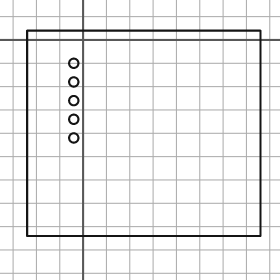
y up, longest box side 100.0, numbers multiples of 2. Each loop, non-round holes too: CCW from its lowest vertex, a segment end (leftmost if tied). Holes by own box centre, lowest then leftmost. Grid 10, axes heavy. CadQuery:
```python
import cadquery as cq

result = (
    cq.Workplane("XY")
    .moveTo(-24.0, -84.0)
    .lineTo(76.0, -84.0)
    .lineTo(76.0, 4.0)
    .lineTo(-24.0, 4.0)
    .close()
    .moveTo(-4.0, -42.0)
    .circle(2.0)
    .moveTo(-4.0, -34.0)
    .circle(2.0)
    .moveTo(-4.0, -26.0)
    .circle(2.0)
    .moveTo(-4.0, -18.0)
    .circle(2.0)
    .moveTo(-4.0, -10.0)
    .circle(2.0)
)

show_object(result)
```